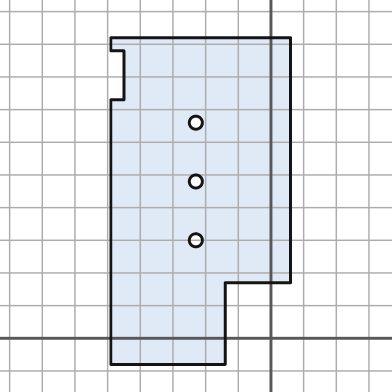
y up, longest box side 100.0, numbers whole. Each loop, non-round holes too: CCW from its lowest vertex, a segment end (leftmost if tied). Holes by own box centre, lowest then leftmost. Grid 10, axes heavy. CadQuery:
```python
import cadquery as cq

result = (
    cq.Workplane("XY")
    .moveTo(-49.0, -8.0)
    .lineTo(-14.0, -8.0)
    .lineTo(-14.0, 17.0)
    .lineTo(6.0, 17.0)
    .lineTo(6.0, 92.0)
    .lineTo(-49.0, 92.0)
    .lineTo(-49.0, 88.0)
    .lineTo(-45.0, 88.0)
    .lineTo(-45.0, 73.0)
    .lineTo(-49.0, 73.0)
    .close()
    .moveTo(-23.0, 30.0)
    .circle(2.0)
    .moveTo(-23.0, 48.0)
    .circle(2.0)
    .moveTo(-23.0, 66.0)
    .circle(2.0)
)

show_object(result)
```